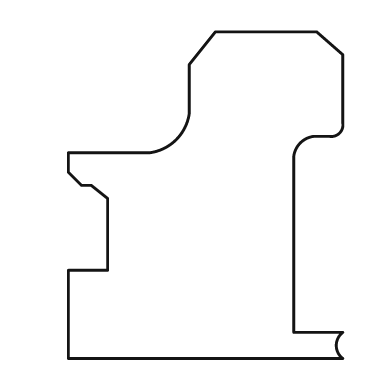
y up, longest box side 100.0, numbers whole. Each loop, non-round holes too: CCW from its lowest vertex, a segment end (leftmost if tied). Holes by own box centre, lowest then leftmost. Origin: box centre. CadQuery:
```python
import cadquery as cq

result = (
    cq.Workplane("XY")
    .moveTo(-42.0, -50.0)
    .lineTo(42.0, -50.0)
    .threePointArc((40.0, -46.0), (42.0, -42.0))
    .lineTo(27.0, -42.0)
    .lineTo(27.0, 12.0)
    .threePointArc((29.0, 16.0), (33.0, 18.0))
    .lineTo(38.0, 18.0)
    .threePointArc((41.0, 19.0), (42.0, 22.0))
    .lineTo(42.0, 43.0)
    .lineTo(34.0, 50.0)
    .lineTo(3.0, 50.0)
    .lineTo(-5.0, 40.0)
    .lineTo(-5.0, 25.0)
    .threePointArc((-9.0, 17.0), (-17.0, 13.0))
    .lineTo(-42.0, 13.0)
    .lineTo(-42.0, 7.0)
    .lineTo(-38.0, 3.0)
    .lineTo(-35.0, 3.0)
    .lineTo(-30.0, -1.0)
    .lineTo(-30.0, -23.0)
    .lineTo(-42.0, -23.0)
    .close()
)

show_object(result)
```